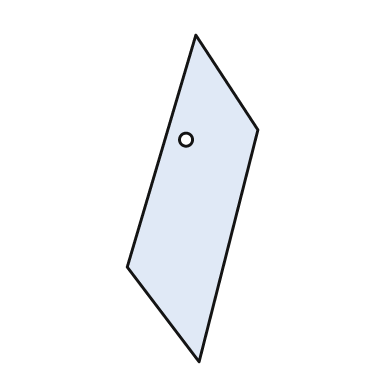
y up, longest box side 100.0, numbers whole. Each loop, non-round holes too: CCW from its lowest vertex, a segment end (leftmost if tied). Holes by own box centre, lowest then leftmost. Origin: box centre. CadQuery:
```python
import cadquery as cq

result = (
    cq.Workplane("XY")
    .moveTo(2.0, -50.0)
    .lineTo(20.0, 21.0)
    .lineTo(1.0, 50.0)
    .lineTo(-20.0, -21.0)
    .close()
    .moveTo(-2.0, 18.0)
    .circle(2.0)
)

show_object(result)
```